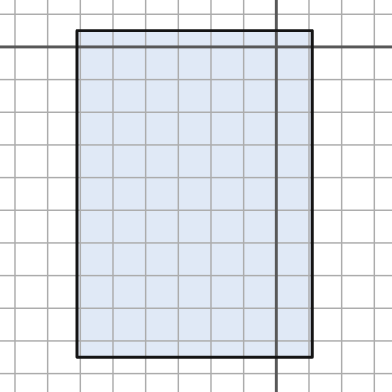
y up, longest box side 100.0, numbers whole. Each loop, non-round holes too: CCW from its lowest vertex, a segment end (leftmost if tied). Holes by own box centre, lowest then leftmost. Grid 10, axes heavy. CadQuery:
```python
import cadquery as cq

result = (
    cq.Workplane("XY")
    .moveTo(-61.0, -95.0)
    .lineTo(11.0, -95.0)
    .lineTo(11.0, 5.0)
    .lineTo(-61.0, 5.0)
    .close()
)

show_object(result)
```